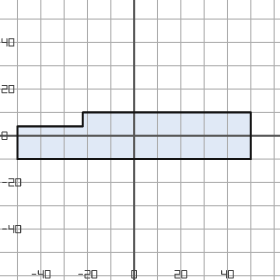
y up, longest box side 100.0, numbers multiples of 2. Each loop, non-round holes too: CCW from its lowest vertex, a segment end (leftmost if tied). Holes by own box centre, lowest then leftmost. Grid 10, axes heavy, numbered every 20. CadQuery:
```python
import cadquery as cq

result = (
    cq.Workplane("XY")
    .moveTo(-50.0, -10.0)
    .lineTo(50.0, -10.0)
    .lineTo(50.0, 10.0)
    .lineTo(-22.0, 10.0)
    .lineTo(-22.0, 4.0)
    .lineTo(-50.0, 4.0)
    .close()
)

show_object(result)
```